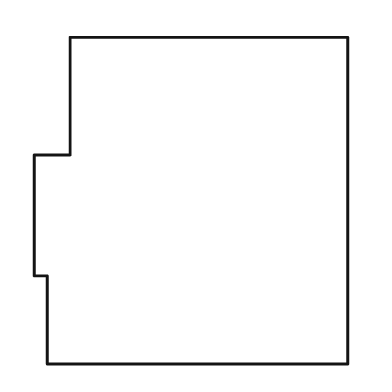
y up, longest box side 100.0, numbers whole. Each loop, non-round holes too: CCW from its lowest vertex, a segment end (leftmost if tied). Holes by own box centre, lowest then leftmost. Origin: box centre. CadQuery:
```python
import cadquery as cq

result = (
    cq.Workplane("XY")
    .moveTo(-44.0, -50.0)
    .lineTo(48.0, -50.0)
    .lineTo(48.0, 50.0)
    .lineTo(-37.0, 50.0)
    .lineTo(-37.0, 14.0)
    .lineTo(-48.0, 14.0)
    .lineTo(-48.0, -23.0)
    .lineTo(-44.0, -23.0)
    .close()
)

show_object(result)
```